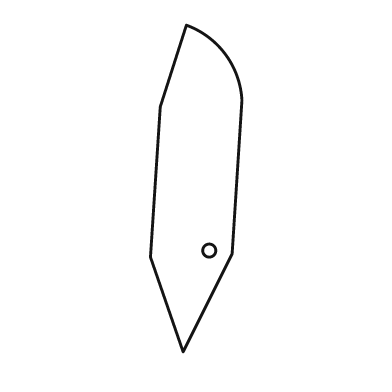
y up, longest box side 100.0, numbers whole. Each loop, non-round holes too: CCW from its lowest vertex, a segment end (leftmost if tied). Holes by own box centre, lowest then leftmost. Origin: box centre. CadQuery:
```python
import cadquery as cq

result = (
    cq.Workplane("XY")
    .moveTo(-4.0, -50.0)
    .lineTo(11.0, -20.0)
    .lineTo(14.0, 27.0)
    .threePointArc((9.0, 41.0), (-3.0, 50.0))
    .lineTo(-11.0, 25.0)
    .lineTo(-14.0, -21.0)
    .close()
    .moveTo(4.0, -19.0)
    .circle(2.0)
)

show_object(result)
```